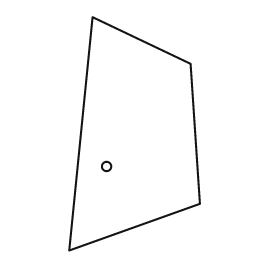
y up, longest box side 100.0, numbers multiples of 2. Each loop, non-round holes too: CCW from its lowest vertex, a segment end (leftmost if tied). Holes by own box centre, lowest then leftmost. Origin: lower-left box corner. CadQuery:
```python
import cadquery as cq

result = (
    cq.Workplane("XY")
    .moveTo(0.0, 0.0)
    .lineTo(56.0, 20.0)
    .lineTo(52.0, 80.0)
    .lineTo(10.0, 100.0)
    .close()
    .moveTo(16.0, 36.0)
    .circle(2.0)
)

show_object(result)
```